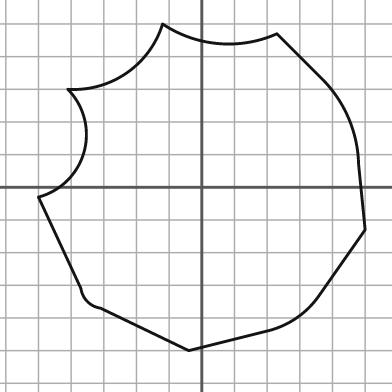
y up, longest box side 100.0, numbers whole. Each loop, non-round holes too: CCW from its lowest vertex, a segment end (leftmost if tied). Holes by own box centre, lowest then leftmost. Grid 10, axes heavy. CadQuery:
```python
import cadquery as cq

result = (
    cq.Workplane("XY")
    .moveTo(-4.0, -50.0)
    .lineTo(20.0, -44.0)
    .threePointArc((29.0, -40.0), (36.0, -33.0))
    .lineTo(50.0, -13.0)
    .lineTo(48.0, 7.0)
    .threePointArc((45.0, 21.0), (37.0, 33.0))
    .lineTo(23.0, 47.0)
    .threePointArc((5.0, 44.0), (-12.0, 50.0))
    .threePointArc((-23.0, 35.0), (-41.0, 30.0))
    .threePointArc((-36.0, 11.0), (-50.0, -3.0))
    .lineTo(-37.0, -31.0)
    .threePointArc((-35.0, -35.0), (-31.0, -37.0))
    .close()
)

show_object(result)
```